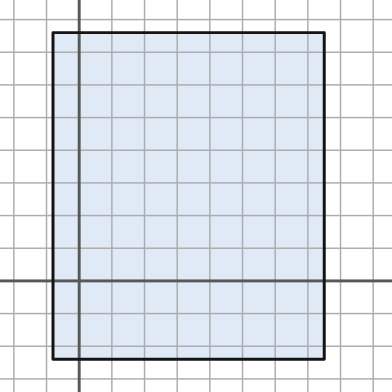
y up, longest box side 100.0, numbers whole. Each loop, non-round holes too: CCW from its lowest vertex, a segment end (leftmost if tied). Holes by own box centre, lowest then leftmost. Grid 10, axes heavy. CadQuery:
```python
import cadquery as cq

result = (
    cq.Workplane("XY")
    .moveTo(-8.0, -24.0)
    .lineTo(75.0, -24.0)
    .lineTo(75.0, 76.0)
    .lineTo(-8.0, 76.0)
    .close()
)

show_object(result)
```